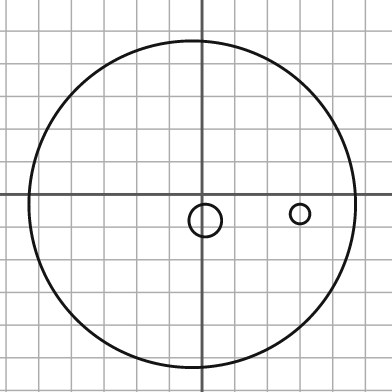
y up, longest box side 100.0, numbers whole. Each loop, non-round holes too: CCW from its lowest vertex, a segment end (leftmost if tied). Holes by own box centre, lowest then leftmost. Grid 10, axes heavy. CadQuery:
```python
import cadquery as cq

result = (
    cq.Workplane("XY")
    .moveTo(-3.0, -3.0)
    .circle(50.0)
    .moveTo(1.0, -8.0)
    .circle(5.0)
    .moveTo(30.0, -6.0)
    .circle(3.0)
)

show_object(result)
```